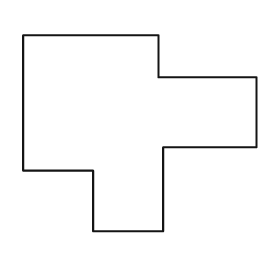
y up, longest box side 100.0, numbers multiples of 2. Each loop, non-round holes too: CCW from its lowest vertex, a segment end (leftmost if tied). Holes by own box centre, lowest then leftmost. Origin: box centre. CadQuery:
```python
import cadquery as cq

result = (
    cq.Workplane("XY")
    .moveTo(-20.0, -42.0)
    .lineTo(10.0, -42.0)
    .lineTo(10.0, -6.0)
    .lineTo(50.0, -6.0)
    .lineTo(50.0, 24.0)
    .lineTo(8.0, 24.0)
    .lineTo(8.0, 42.0)
    .lineTo(-50.0, 42.0)
    .lineTo(-50.0, -16.0)
    .lineTo(-20.0, -16.0)
    .close()
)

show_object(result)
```